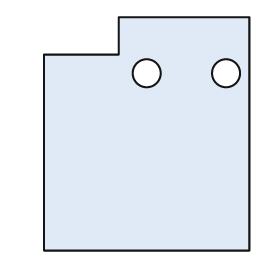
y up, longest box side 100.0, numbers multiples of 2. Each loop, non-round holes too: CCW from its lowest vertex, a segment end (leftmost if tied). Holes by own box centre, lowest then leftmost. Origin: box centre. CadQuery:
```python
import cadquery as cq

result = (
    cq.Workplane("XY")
    .moveTo(-44.0, -50.0)
    .lineTo(44.0, -50.0)
    .lineTo(44.0, 50.0)
    .lineTo(-12.0, 50.0)
    .lineTo(-12.0, 34.0)
    .lineTo(-44.0, 34.0)
    .close()
    .moveTo(0.0, 26.0)
    .circle(6.0)
    .moveTo(34.0, 26.0)
    .circle(6.0)
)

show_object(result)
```